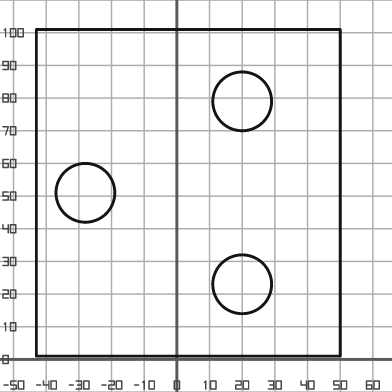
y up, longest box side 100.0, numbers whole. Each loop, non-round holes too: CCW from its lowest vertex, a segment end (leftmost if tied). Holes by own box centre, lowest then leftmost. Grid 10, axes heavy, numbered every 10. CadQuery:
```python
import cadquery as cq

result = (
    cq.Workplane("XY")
    .moveTo(-43.0, 1.0)
    .lineTo(50.0, 1.0)
    .lineTo(50.0, 101.0)
    .lineTo(-43.0, 101.0)
    .close()
    .moveTo(20.0, 23.0)
    .circle(9.0)
    .moveTo(-28.0, 51.0)
    .circle(9.0)
    .moveTo(20.0, 79.0)
    .circle(9.0)
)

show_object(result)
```